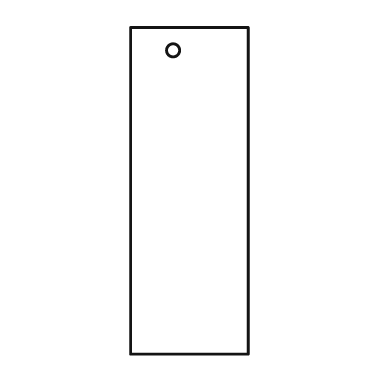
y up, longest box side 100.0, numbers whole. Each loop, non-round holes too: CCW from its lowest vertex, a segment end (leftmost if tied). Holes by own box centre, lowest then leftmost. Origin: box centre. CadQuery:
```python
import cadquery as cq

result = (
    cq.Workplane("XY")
    .moveTo(-18.0, -50.0)
    .lineTo(18.0, -50.0)
    .lineTo(18.0, 50.0)
    .lineTo(-18.0, 50.0)
    .close()
    .moveTo(-5.0, 43.0)
    .circle(2.0)
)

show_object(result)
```